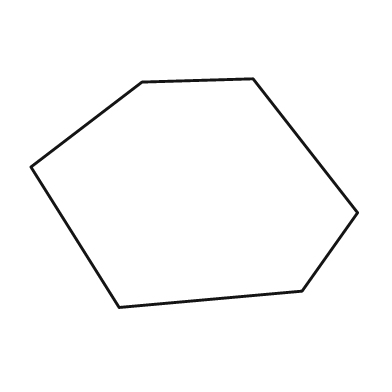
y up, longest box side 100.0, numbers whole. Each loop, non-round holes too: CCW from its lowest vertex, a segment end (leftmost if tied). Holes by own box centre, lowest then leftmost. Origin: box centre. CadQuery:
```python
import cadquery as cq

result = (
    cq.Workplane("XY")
    .moveTo(-23.0, -35.0)
    .lineTo(33.0, -30.0)
    .lineTo(50.0, -6.0)
    .lineTo(18.0, 35.0)
    .lineTo(-16.0, 34.0)
    .lineTo(-50.0, 8.0)
    .close()
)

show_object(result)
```